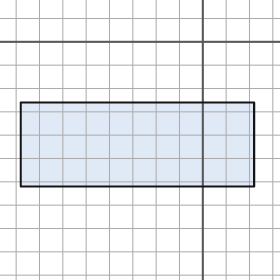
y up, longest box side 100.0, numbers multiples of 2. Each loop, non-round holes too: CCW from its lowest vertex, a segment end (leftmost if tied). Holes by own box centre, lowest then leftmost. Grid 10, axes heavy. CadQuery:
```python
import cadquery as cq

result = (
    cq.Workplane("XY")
    .moveTo(-78.0, -62.0)
    .lineTo(22.0, -62.0)
    .lineTo(22.0, -26.0)
    .lineTo(-78.0, -26.0)
    .close()
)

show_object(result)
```